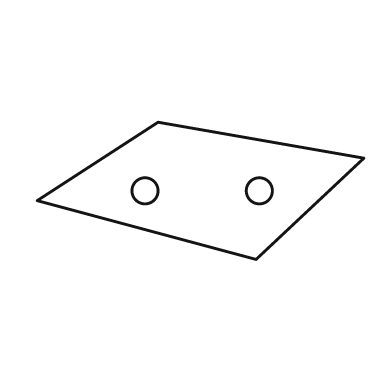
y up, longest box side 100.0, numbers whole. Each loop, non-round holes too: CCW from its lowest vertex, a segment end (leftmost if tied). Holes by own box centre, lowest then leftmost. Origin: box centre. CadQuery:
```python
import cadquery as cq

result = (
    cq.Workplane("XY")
    .moveTo(17.0, -21.0)
    .lineTo(50.0, 10.0)
    .lineTo(-13.0, 21.0)
    .lineTo(-50.0, -3.0)
    .close()
    .moveTo(-17.0, 0.0)
    .circle(4.0)
    .moveTo(18.0, 0.0)
    .circle(4.0)
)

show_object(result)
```